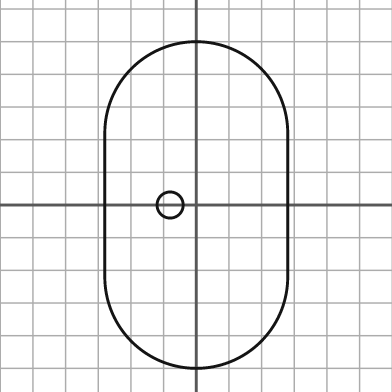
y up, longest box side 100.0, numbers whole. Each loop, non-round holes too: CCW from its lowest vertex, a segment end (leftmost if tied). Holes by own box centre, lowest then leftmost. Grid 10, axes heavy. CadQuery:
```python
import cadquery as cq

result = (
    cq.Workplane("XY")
    .moveTo(-28.0, -22.0)
    .threePointArc((0.0, -50.0), (28.0, -22.0))
    .lineTo(28.0, 22.0)
    .threePointArc((0.0, 50.0), (-28.0, 22.0))
    .close()
    .moveTo(-8.0, 0.0)
    .circle(4.0)
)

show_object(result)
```